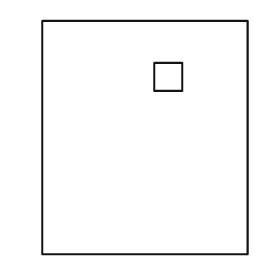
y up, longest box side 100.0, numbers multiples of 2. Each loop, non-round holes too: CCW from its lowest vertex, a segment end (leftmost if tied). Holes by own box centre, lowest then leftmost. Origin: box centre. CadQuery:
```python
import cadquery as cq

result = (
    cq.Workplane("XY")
    .moveTo(-44.0, -50.0)
    .lineTo(44.0, -50.0)
    .lineTo(44.0, 50.0)
    .lineTo(-44.0, 50.0)
    .close()
    .moveTo(4.0, 20.0)
    .lineTo(16.0, 20.0)
    .lineTo(16.0, 32.0)
    .lineTo(4.0, 32.0)
    .close()
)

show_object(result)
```